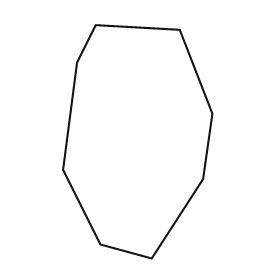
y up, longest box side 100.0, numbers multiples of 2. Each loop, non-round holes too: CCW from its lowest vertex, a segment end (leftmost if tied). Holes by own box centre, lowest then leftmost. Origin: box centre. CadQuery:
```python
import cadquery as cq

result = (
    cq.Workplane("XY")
    .moveTo(6.0, -50.0)
    .lineTo(28.0, -16.0)
    .lineTo(32.0, 12.0)
    .lineTo(18.0, 48.0)
    .lineTo(-18.0, 50.0)
    .lineTo(-26.0, 34.0)
    .lineTo(-32.0, -12.0)
    .lineTo(-16.0, -44.0)
    .close()
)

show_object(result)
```